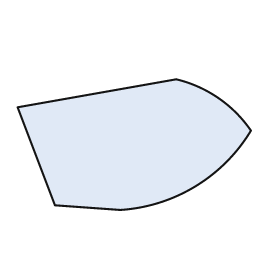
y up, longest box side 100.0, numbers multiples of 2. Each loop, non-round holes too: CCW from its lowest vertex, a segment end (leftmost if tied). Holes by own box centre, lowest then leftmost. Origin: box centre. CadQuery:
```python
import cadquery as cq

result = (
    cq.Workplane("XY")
    .moveTo(-6.0, -28.0)
    .threePointArc((26.0, -18.0), (50.0, 6.0))
    .threePointArc((36.0, 20.0), (18.0, 28.0))
    .lineTo(-50.0, 16.0)
    .lineTo(-34.0, -26.0)
    .close()
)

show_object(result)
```